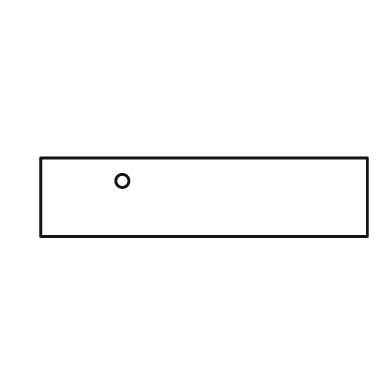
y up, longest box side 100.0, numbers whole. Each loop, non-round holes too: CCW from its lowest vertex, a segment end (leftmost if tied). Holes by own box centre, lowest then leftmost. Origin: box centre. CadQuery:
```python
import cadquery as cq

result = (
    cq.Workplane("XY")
    .moveTo(-50.0, -12.0)
    .lineTo(50.0, -12.0)
    .lineTo(50.0, 12.0)
    .lineTo(-50.0, 12.0)
    .close()
    .moveTo(-25.0, 5.0)
    .circle(2.0)
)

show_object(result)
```